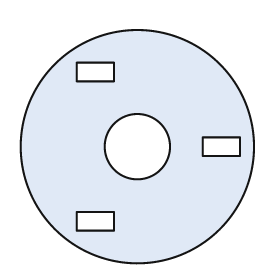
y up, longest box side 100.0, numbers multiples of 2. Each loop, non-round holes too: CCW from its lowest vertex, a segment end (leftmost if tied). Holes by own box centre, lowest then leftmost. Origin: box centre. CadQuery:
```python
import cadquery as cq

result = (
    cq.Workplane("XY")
    .moveTo(0.0, 0.0)
    .circle(50.0)
    .moveTo(-26.0, -36.0)
    .lineTo(-10.0, -36.0)
    .lineTo(-10.0, -28.0)
    .lineTo(-26.0, -28.0)
    .close()
    .moveTo(0.0, 0.0)
    .circle(14.0)
    .moveTo(28.0, -4.0)
    .lineTo(44.0, -4.0)
    .lineTo(44.0, 4.0)
    .lineTo(28.0, 4.0)
    .close()
    .moveTo(-26.0, 28.0)
    .lineTo(-10.0, 28.0)
    .lineTo(-10.0, 36.0)
    .lineTo(-26.0, 36.0)
    .close()
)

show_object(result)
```